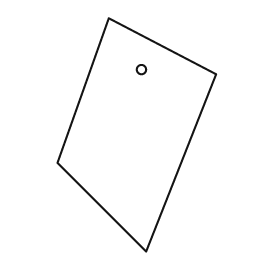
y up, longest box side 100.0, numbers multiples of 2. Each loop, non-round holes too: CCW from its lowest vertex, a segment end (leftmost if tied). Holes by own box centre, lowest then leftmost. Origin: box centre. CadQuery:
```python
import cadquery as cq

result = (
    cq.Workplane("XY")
    .moveTo(4.0, -50.0)
    .lineTo(34.0, 26.0)
    .lineTo(-12.0, 50.0)
    .lineTo(-34.0, -12.0)
    .close()
    .moveTo(2.0, 28.0)
    .circle(2.0)
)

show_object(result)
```